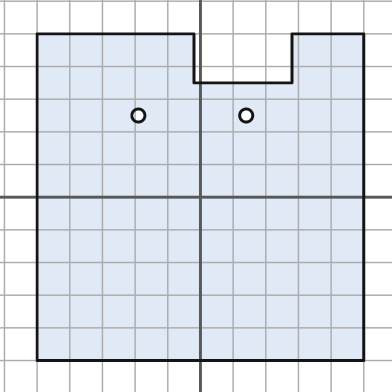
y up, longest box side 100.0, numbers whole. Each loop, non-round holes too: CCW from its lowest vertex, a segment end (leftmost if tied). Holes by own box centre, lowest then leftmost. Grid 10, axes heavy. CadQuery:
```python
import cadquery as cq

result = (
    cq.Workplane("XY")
    .moveTo(-50.0, -50.0)
    .lineTo(50.0, -50.0)
    .lineTo(50.0, 50.0)
    .lineTo(28.0, 50.0)
    .lineTo(28.0, 35.0)
    .lineTo(-2.0, 35.0)
    .lineTo(-2.0, 50.0)
    .lineTo(-50.0, 50.0)
    .close()
    .moveTo(-19.0, 25.0)
    .circle(2.0)
    .moveTo(14.0, 25.0)
    .circle(2.0)
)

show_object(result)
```